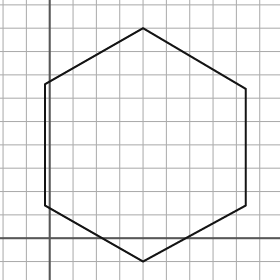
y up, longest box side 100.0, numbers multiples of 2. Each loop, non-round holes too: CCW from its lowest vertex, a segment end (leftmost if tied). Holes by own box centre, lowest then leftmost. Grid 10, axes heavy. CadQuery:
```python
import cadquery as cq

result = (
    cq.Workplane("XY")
    .moveTo(40.0, -10.0)
    .lineTo(84.0, 14.0)
    .lineTo(84.0, 64.0)
    .lineTo(40.0, 90.0)
    .lineTo(-2.0, 66.0)
    .lineTo(-2.0, 14.0)
    .close()
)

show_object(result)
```